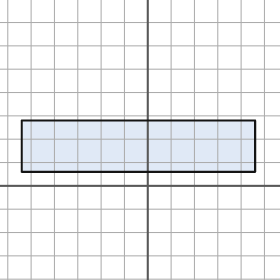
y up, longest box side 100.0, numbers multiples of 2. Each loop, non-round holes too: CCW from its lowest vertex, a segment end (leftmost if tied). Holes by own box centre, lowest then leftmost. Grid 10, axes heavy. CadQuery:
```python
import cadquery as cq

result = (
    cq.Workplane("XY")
    .moveTo(-54.0, 6.0)
    .lineTo(46.0, 6.0)
    .lineTo(46.0, 28.0)
    .lineTo(-54.0, 28.0)
    .close()
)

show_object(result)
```